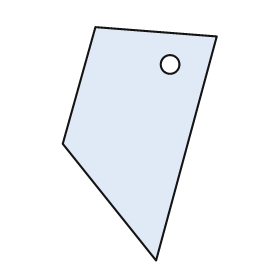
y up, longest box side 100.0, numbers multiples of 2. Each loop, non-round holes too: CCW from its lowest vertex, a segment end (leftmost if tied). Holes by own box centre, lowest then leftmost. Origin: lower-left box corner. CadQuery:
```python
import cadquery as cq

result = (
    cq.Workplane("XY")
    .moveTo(40.0, 0.0)
    .lineTo(66.0, 96.0)
    .lineTo(14.0, 100.0)
    .lineTo(0.0, 50.0)
    .close()
    .moveTo(46.0, 84.0)
    .circle(4.0)
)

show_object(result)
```